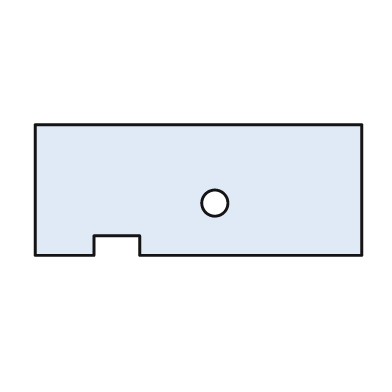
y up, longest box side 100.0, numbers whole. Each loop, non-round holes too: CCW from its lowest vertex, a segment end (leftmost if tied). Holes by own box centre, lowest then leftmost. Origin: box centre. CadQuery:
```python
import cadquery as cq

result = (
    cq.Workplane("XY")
    .moveTo(-50.0, -20.0)
    .lineTo(-32.0, -20.0)
    .lineTo(-32.0, -14.0)
    .lineTo(-18.0, -14.0)
    .lineTo(-18.0, -20.0)
    .lineTo(50.0, -20.0)
    .lineTo(50.0, 20.0)
    .lineTo(-50.0, 20.0)
    .close()
    .moveTo(5.0, -4.0)
    .circle(4.0)
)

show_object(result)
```